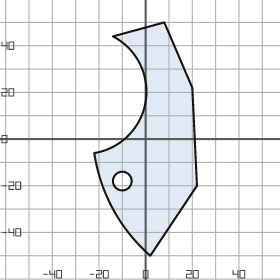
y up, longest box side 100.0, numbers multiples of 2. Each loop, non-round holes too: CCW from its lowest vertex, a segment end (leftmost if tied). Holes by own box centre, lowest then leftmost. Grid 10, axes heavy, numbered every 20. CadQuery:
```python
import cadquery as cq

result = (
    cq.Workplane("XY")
    .moveTo(2.0, -50.0)
    .lineTo(22.0, -20.0)
    .lineTo(20.0, 22.0)
    .lineTo(8.0, 50.0)
    .lineTo(-14.0, 44.0)
    .threePointArc((0.0, 16.0), (-22.0, -6.0))
    .threePointArc((-14.0, -30.0), (2.0, -50.0))
    .close()
    .moveTo(-10.0, -18.0)
    .circle(4.0)
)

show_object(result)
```